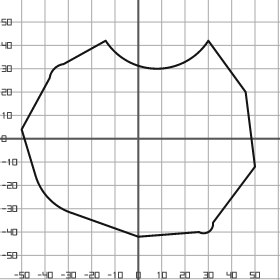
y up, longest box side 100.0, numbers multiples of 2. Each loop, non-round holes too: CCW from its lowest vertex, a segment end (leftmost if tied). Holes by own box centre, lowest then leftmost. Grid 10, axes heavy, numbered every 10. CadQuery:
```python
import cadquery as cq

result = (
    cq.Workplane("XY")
    .moveTo(0.0, -42.0)
    .lineTo(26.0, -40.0)
    .threePointArc((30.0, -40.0), (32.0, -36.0))
    .lineTo(50.0, -12.0)
    .lineTo(46.0, 20.0)
    .lineTo(30.0, 42.0)
    .threePointArc((8.0, 30.0), (-14.0, 42.0))
    .lineTo(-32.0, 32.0)
    .threePointArc((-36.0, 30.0), (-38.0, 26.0))
    .lineTo(-50.0, 4.0)
    .lineTo(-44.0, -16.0)
    .threePointArc((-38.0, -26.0), (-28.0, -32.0))
    .close()
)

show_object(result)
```